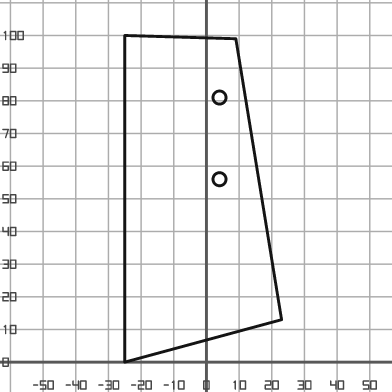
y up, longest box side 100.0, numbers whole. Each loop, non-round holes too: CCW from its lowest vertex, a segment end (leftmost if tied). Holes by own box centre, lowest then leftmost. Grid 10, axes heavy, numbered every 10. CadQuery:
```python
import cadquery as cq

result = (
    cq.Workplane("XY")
    .moveTo(-25.0, 0.0)
    .lineTo(23.0, 13.0)
    .lineTo(9.0, 99.0)
    .lineTo(-25.0, 100.0)
    .close()
    .moveTo(4.0, 56.0)
    .circle(2.0)
    .moveTo(4.0, 81.0)
    .circle(2.0)
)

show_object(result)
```